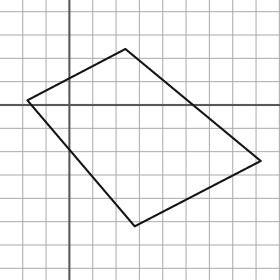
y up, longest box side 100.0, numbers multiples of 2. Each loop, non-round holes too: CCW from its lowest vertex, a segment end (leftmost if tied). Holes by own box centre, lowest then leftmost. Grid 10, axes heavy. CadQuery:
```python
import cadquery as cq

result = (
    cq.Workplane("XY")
    .moveTo(28.0, -52.0)
    .lineTo(82.0, -24.0)
    .lineTo(24.0, 24.0)
    .lineTo(-18.0, 2.0)
    .close()
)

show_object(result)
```